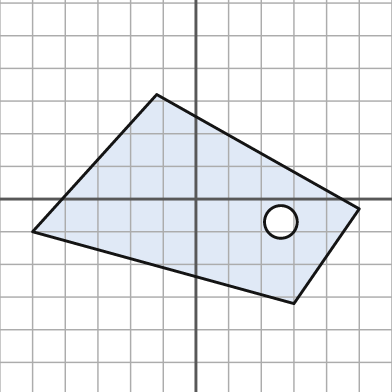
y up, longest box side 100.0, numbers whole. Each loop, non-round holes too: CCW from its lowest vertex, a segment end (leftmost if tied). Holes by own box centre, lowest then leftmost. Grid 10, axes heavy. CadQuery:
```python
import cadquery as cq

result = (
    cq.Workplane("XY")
    .moveTo(30.0, -32.0)
    .lineTo(50.0, -3.0)
    .lineTo(-12.0, 32.0)
    .lineTo(-50.0, -10.0)
    .close()
    .moveTo(26.0, -7.0)
    .circle(5.0)
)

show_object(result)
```